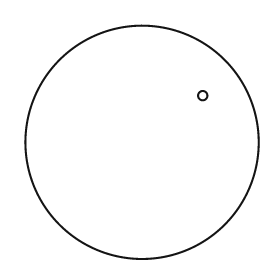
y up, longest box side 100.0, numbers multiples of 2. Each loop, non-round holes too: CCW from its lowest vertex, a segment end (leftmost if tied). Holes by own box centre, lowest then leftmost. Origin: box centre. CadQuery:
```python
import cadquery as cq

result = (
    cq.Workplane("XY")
    .moveTo(0.0, 0.0)
    .circle(50.0)
    .moveTo(26.0, 20.0)
    .circle(2.0)
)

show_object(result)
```